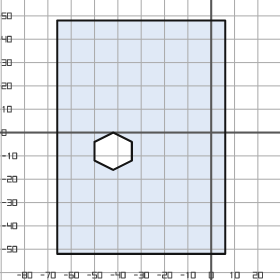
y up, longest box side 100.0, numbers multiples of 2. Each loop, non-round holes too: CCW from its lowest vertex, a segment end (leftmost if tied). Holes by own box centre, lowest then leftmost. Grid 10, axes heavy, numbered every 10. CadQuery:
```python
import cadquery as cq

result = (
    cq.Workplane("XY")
    .moveTo(-66.0, -52.0)
    .lineTo(6.0, -52.0)
    .lineTo(6.0, 48.0)
    .lineTo(-66.0, 48.0)
    .close()
    .moveTo(-42.0, -16.0)
    .lineTo(-34.0, -12.0)
    .lineTo(-34.0, -4.0)
    .lineTo(-42.0, 0.0)
    .lineTo(-50.0, -4.0)
    .lineTo(-50.0, -12.0)
    .close()
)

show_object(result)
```